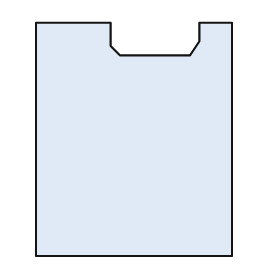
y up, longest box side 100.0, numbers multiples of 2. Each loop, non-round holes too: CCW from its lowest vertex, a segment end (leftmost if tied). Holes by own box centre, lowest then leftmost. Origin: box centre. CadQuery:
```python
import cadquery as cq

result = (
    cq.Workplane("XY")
    .moveTo(-42.0, -50.0)
    .lineTo(42.0, -50.0)
    .lineTo(42.0, 50.0)
    .lineTo(28.0, 50.0)
    .lineTo(28.0, 42.0)
    .lineTo(24.0, 36.0)
    .lineTo(-6.0, 36.0)
    .lineTo(-10.0, 40.0)
    .lineTo(-10.0, 50.0)
    .lineTo(-42.0, 50.0)
    .close()
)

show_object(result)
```